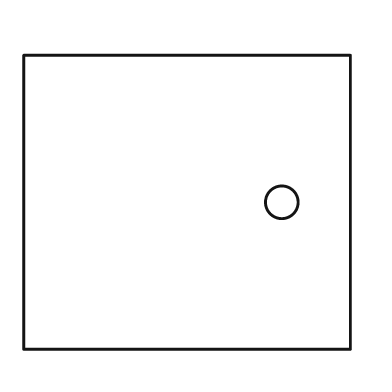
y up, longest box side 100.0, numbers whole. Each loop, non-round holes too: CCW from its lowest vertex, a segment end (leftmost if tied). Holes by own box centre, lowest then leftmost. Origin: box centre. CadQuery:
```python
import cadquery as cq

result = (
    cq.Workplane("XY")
    .moveTo(-50.0, -45.0)
    .lineTo(50.0, -45.0)
    .lineTo(50.0, 45.0)
    .lineTo(-50.0, 45.0)
    .close()
    .moveTo(29.0, 0.0)
    .circle(5.0)
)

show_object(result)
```